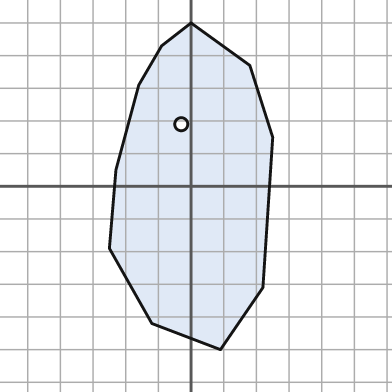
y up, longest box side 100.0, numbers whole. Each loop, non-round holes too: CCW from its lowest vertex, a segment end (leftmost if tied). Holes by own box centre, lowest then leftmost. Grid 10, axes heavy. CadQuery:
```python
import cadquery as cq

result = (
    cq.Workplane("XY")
    .moveTo(9.0, -50.0)
    .lineTo(22.0, -31.0)
    .lineTo(25.0, 15.0)
    .lineTo(18.0, 37.0)
    .lineTo(0.0, 50.0)
    .lineTo(-9.0, 43.0)
    .lineTo(-16.0, 31.0)
    .lineTo(-23.0, 5.0)
    .lineTo(-25.0, -19.0)
    .lineTo(-12.0, -42.0)
    .close()
    .moveTo(-3.0, 19.0)
    .circle(2.0)
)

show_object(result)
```